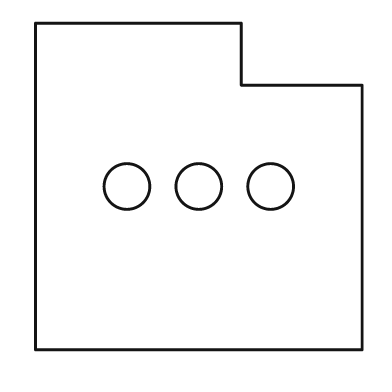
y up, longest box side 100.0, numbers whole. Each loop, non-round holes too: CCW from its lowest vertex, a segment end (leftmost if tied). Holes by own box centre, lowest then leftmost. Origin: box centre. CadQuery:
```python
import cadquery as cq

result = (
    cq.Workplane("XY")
    .moveTo(-50.0, -50.0)
    .lineTo(50.0, -50.0)
    .lineTo(50.0, 31.0)
    .lineTo(13.0, 31.0)
    .lineTo(13.0, 50.0)
    .lineTo(-50.0, 50.0)
    .close()
    .moveTo(-22.0, 0.0)
    .circle(7.0)
    .moveTo(0.0, 0.0)
    .circle(7.0)
    .moveTo(22.0, 0.0)
    .circle(7.0)
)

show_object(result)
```